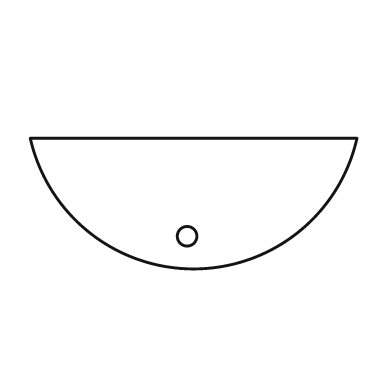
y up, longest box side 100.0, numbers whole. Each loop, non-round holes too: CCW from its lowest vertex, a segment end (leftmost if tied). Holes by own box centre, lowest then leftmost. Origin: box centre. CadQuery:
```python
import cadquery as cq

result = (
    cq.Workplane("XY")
    .moveTo(-50.0, 20.0)
    .threePointArc((0.0, -20.0), (50.0, 20.0))
    .close()
    .moveTo(-2.0, -10.0)
    .circle(3.0)
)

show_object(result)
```